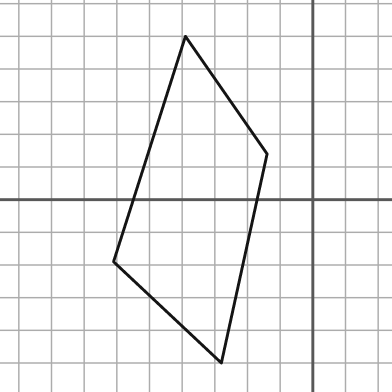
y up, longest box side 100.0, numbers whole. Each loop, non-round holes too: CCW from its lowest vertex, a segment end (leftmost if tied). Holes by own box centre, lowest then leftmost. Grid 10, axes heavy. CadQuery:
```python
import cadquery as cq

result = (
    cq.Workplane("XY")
    .moveTo(-28.0, -50.0)
    .lineTo(-14.0, 14.0)
    .lineTo(-39.0, 50.0)
    .lineTo(-61.0, -19.0)
    .close()
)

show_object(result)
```